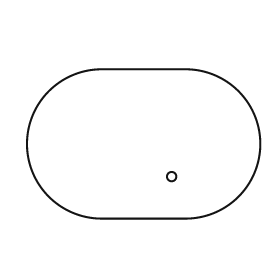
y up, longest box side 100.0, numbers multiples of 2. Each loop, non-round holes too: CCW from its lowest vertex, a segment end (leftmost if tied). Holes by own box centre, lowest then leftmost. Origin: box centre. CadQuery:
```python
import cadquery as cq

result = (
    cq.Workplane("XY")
    .moveTo(-18.0, -32.0)
    .lineTo(18.0, -32.0)
    .threePointArc((50.0, 0.0), (18.0, 32.0))
    .lineTo(-18.0, 32.0)
    .threePointArc((-50.0, 0.0), (-18.0, -32.0))
    .close()
    .moveTo(12.0, -14.0)
    .circle(2.0)
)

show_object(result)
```